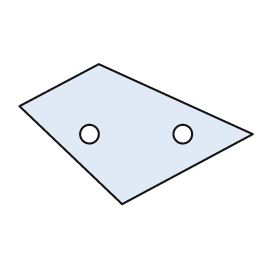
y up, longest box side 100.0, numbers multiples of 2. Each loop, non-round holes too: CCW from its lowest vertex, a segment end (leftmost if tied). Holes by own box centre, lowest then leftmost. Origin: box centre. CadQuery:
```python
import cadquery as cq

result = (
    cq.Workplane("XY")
    .moveTo(-6.0, -30.0)
    .lineTo(50.0, 0.0)
    .lineTo(-16.0, 30.0)
    .lineTo(-50.0, 12.0)
    .close()
    .moveTo(-20.0, 0.0)
    .circle(4.0)
    .moveTo(20.0, 0.0)
    .circle(4.0)
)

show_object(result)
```